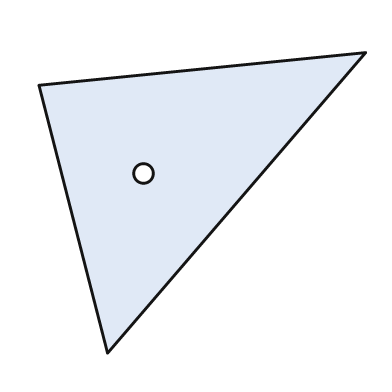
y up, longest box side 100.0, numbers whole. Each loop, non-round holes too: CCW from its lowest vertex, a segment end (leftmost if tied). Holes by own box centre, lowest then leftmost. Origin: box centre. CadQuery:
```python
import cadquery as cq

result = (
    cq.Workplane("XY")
    .moveTo(-29.0, -46.0)
    .lineTo(50.0, 46.0)
    .lineTo(-50.0, 36.0)
    .close()
    .moveTo(-18.0, 9.0)
    .circle(3.0)
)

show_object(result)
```